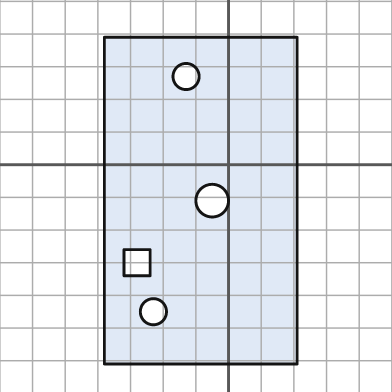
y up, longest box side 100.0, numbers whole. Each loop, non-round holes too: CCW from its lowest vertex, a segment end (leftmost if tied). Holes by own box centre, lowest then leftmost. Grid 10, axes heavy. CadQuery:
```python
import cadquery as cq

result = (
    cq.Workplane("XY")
    .moveTo(-38.0, -61.0)
    .lineTo(21.0, -61.0)
    .lineTo(21.0, 39.0)
    .lineTo(-38.0, 39.0)
    .close()
    .moveTo(-23.0, -45.0)
    .circle(4.0)
    .moveTo(-32.0, -34.0)
    .lineTo(-24.0, -34.0)
    .lineTo(-24.0, -26.0)
    .lineTo(-32.0, -26.0)
    .close()
    .moveTo(-5.0, -11.0)
    .circle(5.0)
    .moveTo(-13.0, 27.0)
    .circle(4.0)
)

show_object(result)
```